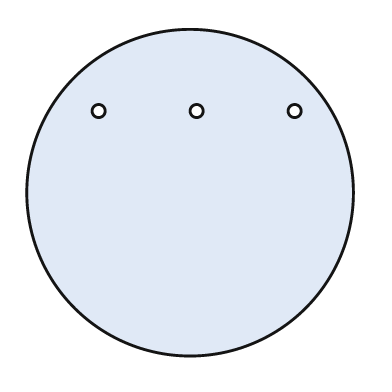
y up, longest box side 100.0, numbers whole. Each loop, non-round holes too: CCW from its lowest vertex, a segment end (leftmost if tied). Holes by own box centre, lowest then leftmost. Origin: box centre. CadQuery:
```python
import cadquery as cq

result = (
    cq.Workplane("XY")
    .moveTo(0.0, 0.0)
    .circle(50.0)
    .moveTo(-28.0, 25.0)
    .circle(2.0)
    .moveTo(2.0, 25.0)
    .circle(2.0)
    .moveTo(32.0, 25.0)
    .circle(2.0)
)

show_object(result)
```